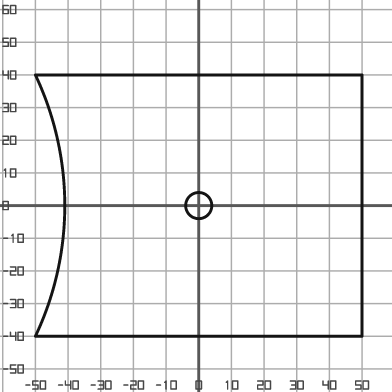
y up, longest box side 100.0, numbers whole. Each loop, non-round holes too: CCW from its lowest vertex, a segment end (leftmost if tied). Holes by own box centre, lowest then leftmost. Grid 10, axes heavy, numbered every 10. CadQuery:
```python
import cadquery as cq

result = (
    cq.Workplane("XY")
    .moveTo(-50.0, -40.0)
    .lineTo(50.0, -40.0)
    .lineTo(50.0, 40.0)
    .lineTo(-50.0, 40.0)
    .threePointArc((-41.0, 0.0), (-50.0, -40.0))
    .close()
    .moveTo(0.0, 0.0)
    .circle(4.0)
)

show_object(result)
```